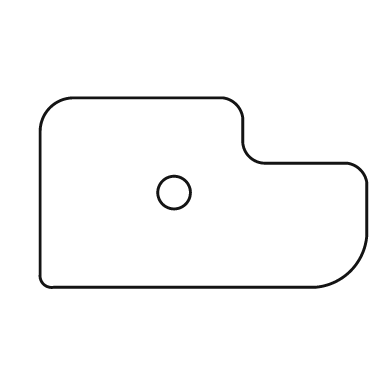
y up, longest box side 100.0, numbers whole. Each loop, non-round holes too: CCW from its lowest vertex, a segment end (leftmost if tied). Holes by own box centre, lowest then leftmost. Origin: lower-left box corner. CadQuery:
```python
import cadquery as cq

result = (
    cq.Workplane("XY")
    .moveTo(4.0, 0.0)
    .lineTo(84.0, 0.0)
    .threePointArc((95.0, 5.0), (100.0, 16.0))
    .lineTo(100.0, 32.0)
    .threePointArc((98.0, 36.0), (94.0, 38.0))
    .lineTo(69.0, 38.0)
    .threePointArc((64.0, 40.0), (62.0, 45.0))
    .lineTo(62.0, 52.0)
    .threePointArc((60.0, 56.0), (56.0, 58.0))
    .lineTo(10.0, 58.0)
    .threePointArc((3.0, 55.0), (0.0, 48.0))
    .lineTo(0.0, 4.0)
    .threePointArc((1.0, 1.0), (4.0, 0.0))
    .close()
    .moveTo(41.0, 29.0)
    .circle(5.0)
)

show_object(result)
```